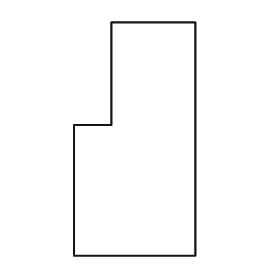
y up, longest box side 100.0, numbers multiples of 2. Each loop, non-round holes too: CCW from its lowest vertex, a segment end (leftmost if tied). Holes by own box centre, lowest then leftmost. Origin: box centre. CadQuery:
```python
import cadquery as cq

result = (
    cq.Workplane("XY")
    .moveTo(-26.0, -50.0)
    .lineTo(26.0, -50.0)
    .lineTo(26.0, 50.0)
    .lineTo(-10.0, 50.0)
    .lineTo(-10.0, 6.0)
    .lineTo(-26.0, 6.0)
    .close()
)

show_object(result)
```